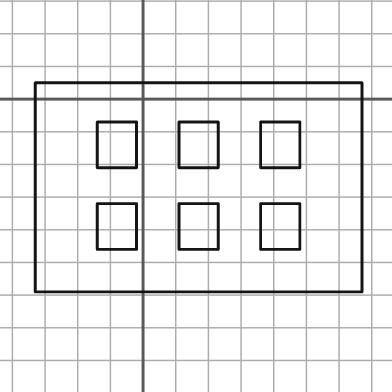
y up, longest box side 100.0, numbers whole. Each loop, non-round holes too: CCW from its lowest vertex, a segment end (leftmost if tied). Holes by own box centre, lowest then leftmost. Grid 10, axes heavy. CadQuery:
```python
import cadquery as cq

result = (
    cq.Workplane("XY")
    .moveTo(-33.0, -59.0)
    .lineTo(67.0, -59.0)
    .lineTo(67.0, 5.0)
    .lineTo(-33.0, 5.0)
    .close()
    .moveTo(-14.0, -46.0)
    .lineTo(-2.0, -46.0)
    .lineTo(-2.0, -32.0)
    .lineTo(-14.0, -32.0)
    .close()
    .moveTo(11.0, -46.0)
    .lineTo(23.0, -46.0)
    .lineTo(23.0, -32.0)
    .lineTo(11.0, -32.0)
    .close()
    .moveTo(36.0, -46.0)
    .lineTo(48.0, -46.0)
    .lineTo(48.0, -32.0)
    .lineTo(36.0, -32.0)
    .close()
    .moveTo(-14.0, -21.0)
    .lineTo(-2.0, -21.0)
    .lineTo(-2.0, -7.0)
    .lineTo(-14.0, -7.0)
    .close()
    .moveTo(11.0, -21.0)
    .lineTo(23.0, -21.0)
    .lineTo(23.0, -7.0)
    .lineTo(11.0, -7.0)
    .close()
    .moveTo(36.0, -21.0)
    .lineTo(48.0, -21.0)
    .lineTo(48.0, -7.0)
    .lineTo(36.0, -7.0)
    .close()
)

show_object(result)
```